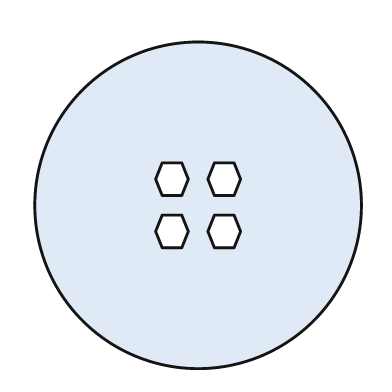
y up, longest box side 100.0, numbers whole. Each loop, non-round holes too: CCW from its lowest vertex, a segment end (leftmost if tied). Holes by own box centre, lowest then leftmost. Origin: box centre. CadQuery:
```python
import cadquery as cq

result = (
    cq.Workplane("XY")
    .moveTo(0.0, 0.0)
    .circle(50.0)
    .moveTo(-11.0, -13.0)
    .lineTo(-5.0, -13.0)
    .lineTo(-3.0, -8.0)
    .lineTo(-5.0, -3.0)
    .lineTo(-11.0, -3.0)
    .lineTo(-13.0, -8.0)
    .close()
    .moveTo(5.0, -13.0)
    .lineTo(11.0, -13.0)
    .lineTo(13.0, -8.0)
    .lineTo(11.0, -3.0)
    .lineTo(5.0, -3.0)
    .lineTo(3.0, -8.0)
    .close()
    .moveTo(-11.0, 3.0)
    .lineTo(-5.0, 3.0)
    .lineTo(-3.0, 8.0)
    .lineTo(-5.0, 13.0)
    .lineTo(-11.0, 13.0)
    .lineTo(-13.0, 8.0)
    .close()
    .moveTo(5.0, 3.0)
    .lineTo(11.0, 3.0)
    .lineTo(13.0, 8.0)
    .lineTo(11.0, 13.0)
    .lineTo(5.0, 13.0)
    .lineTo(3.0, 8.0)
    .close()
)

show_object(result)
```